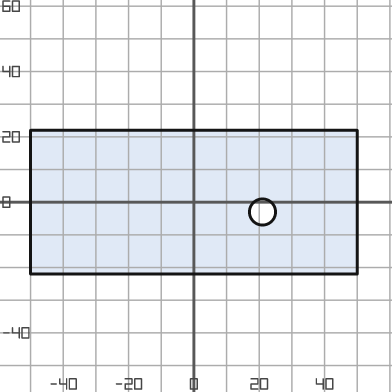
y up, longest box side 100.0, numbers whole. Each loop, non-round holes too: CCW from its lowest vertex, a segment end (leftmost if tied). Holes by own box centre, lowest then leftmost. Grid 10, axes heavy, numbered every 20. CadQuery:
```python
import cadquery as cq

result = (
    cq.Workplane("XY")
    .moveTo(-50.0, -22.0)
    .lineTo(50.0, -22.0)
    .lineTo(50.0, 22.0)
    .lineTo(-50.0, 22.0)
    .close()
    .moveTo(21.0, -3.0)
    .circle(4.0)
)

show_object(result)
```